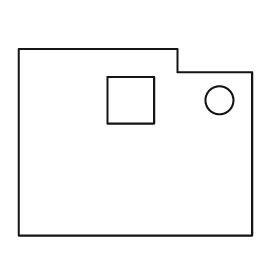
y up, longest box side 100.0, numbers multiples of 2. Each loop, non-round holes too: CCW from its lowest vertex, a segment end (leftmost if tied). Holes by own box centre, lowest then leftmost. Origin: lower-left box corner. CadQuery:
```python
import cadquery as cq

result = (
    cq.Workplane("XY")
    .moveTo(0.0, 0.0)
    .lineTo(100.0, 0.0)
    .lineTo(100.0, 70.0)
    .lineTo(68.0, 70.0)
    .lineTo(68.0, 80.0)
    .lineTo(0.0, 80.0)
    .close()
    .moveTo(38.0, 48.0)
    .lineTo(58.0, 48.0)
    .lineTo(58.0, 68.0)
    .lineTo(38.0, 68.0)
    .close()
    .moveTo(86.0, 58.0)
    .circle(6.0)
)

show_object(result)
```